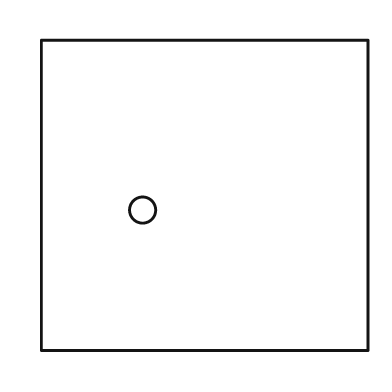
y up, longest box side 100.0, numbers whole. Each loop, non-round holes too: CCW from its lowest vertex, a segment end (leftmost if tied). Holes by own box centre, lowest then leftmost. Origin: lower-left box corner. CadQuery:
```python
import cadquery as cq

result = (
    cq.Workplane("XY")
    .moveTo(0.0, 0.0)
    .lineTo(100.0, 0.0)
    .lineTo(100.0, 95.0)
    .lineTo(0.0, 95.0)
    .close()
    .moveTo(31.0, 43.0)
    .circle(4.0)
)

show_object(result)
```